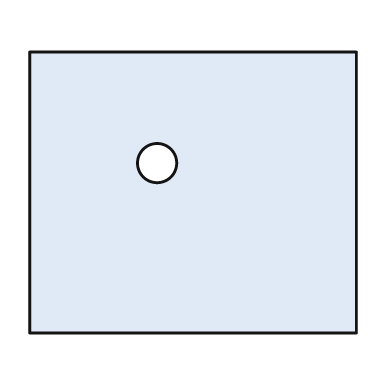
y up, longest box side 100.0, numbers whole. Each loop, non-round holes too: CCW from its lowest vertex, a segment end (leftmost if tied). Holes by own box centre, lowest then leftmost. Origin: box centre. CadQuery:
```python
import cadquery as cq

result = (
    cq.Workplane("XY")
    .moveTo(-50.0, -43.0)
    .lineTo(50.0, -43.0)
    .lineTo(50.0, 43.0)
    .lineTo(-50.0, 43.0)
    .close()
    .moveTo(-11.0, 9.0)
    .circle(6.0)
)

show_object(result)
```